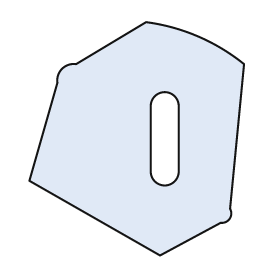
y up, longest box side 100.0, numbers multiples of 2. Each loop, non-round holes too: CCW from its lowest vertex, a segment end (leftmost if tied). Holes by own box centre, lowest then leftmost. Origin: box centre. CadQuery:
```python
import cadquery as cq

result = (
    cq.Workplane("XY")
    .moveTo(10.0, -50.0)
    .lineTo(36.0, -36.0)
    .threePointArc((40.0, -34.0), (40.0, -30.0))
    .lineTo(46.0, 32.0)
    .threePointArc((26.0, 44.0), (4.0, 50.0))
    .lineTo(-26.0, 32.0)
    .threePointArc((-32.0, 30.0), (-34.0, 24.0))
    .lineTo(-46.0, -18.0)
    .close()
    .moveTo(6.0, -14.0)
    .threePointArc((12.0, -20.0), (18.0, -14.0))
    .lineTo(18.0, 14.0)
    .threePointArc((12.0, 20.0), (6.0, 14.0))
    .close()
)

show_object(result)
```